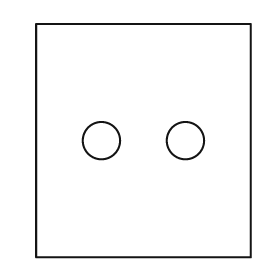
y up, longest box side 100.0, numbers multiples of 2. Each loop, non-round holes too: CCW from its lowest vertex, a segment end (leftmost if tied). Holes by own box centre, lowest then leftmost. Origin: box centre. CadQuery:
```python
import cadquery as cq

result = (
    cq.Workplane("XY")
    .moveTo(-46.0, -50.0)
    .lineTo(46.0, -50.0)
    .lineTo(46.0, 50.0)
    .lineTo(-46.0, 50.0)
    .close()
    .moveTo(-18.0, 0.0)
    .circle(8.0)
    .moveTo(18.0, 0.0)
    .circle(8.0)
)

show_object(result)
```